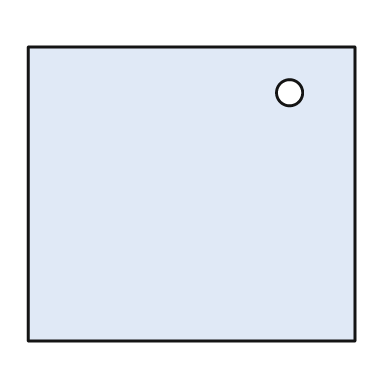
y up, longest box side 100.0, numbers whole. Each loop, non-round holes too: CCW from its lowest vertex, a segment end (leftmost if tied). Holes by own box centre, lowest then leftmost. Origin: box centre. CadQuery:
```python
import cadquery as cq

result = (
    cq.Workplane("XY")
    .moveTo(-50.0, -45.0)
    .lineTo(50.0, -45.0)
    .lineTo(50.0, 45.0)
    .lineTo(-50.0, 45.0)
    .close()
    .moveTo(30.0, 31.0)
    .circle(4.0)
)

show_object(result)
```